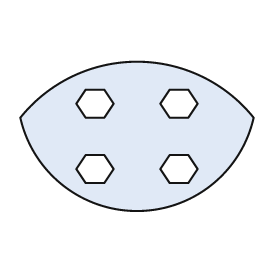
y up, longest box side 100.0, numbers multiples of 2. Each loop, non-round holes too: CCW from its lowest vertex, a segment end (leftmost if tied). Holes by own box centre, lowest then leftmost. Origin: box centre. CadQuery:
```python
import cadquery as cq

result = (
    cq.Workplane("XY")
    .moveTo(-50.0, 8.0)
    .threePointArc((0.0, -32.0), (50.0, 8.0))
    .threePointArc((0.0, 32.0), (-50.0, 8.0))
    .close()
    .moveTo(-22.0, -20.0)
    .lineTo(-14.0, -20.0)
    .lineTo(-10.0, -14.0)
    .lineTo(-14.0, -8.0)
    .lineTo(-22.0, -8.0)
    .lineTo(-26.0, -14.0)
    .close()
    .moveTo(14.0, -20.0)
    .lineTo(22.0, -20.0)
    .lineTo(26.0, -14.0)
    .lineTo(22.0, -8.0)
    .lineTo(14.0, -8.0)
    .lineTo(10.0, -14.0)
    .close()
    .moveTo(-22.0, 8.0)
    .lineTo(-14.0, 8.0)
    .lineTo(-10.0, 14.0)
    .lineTo(-14.0, 20.0)
    .lineTo(-22.0, 20.0)
    .lineTo(-26.0, 14.0)
    .close()
    .moveTo(14.0, 8.0)
    .lineTo(22.0, 8.0)
    .lineTo(26.0, 14.0)
    .lineTo(22.0, 20.0)
    .lineTo(14.0, 20.0)
    .lineTo(10.0, 14.0)
    .close()
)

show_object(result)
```